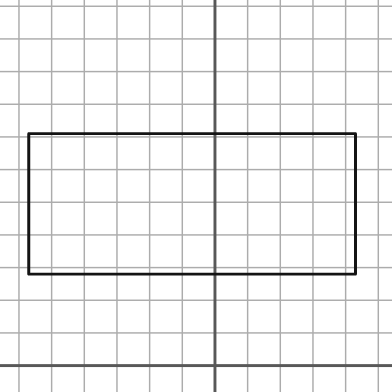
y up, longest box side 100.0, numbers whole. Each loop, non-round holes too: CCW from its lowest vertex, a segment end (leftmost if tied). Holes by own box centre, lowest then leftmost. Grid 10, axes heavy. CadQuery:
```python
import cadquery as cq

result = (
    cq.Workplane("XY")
    .moveTo(-57.0, 28.0)
    .lineTo(43.0, 28.0)
    .lineTo(43.0, 71.0)
    .lineTo(-57.0, 71.0)
    .close()
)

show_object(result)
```